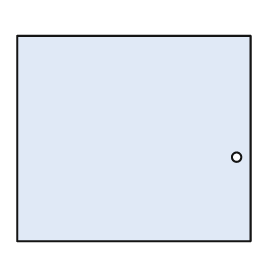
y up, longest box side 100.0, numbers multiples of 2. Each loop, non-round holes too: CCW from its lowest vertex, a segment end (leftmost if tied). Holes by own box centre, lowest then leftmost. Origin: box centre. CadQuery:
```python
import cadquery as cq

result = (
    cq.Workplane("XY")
    .moveTo(-50.0, -44.0)
    .lineTo(50.0, -44.0)
    .lineTo(50.0, 44.0)
    .lineTo(-50.0, 44.0)
    .close()
    .moveTo(44.0, -8.0)
    .circle(2.0)
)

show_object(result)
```